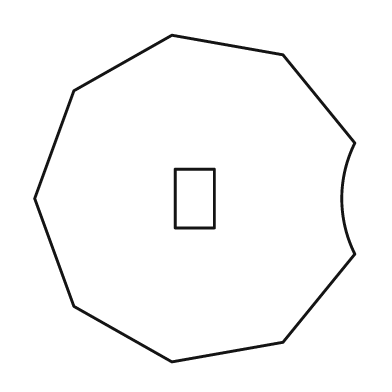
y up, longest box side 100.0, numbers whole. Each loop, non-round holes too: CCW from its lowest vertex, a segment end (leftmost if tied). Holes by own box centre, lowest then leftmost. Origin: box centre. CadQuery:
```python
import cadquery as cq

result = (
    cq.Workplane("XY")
    .moveTo(-7.0, -50.0)
    .lineTo(27.0, -44.0)
    .lineTo(49.0, -17.0)
    .threePointArc((45.0, 0.0), (49.0, 17.0))
    .lineTo(27.0, 44.0)
    .lineTo(-7.0, 50.0)
    .lineTo(-37.0, 33.0)
    .lineTo(-49.0, 0.0)
    .lineTo(-37.0, -33.0)
    .close()
    .moveTo(-6.0, -9.0)
    .lineTo(6.0, -9.0)
    .lineTo(6.0, 9.0)
    .lineTo(-6.0, 9.0)
    .close()
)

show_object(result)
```